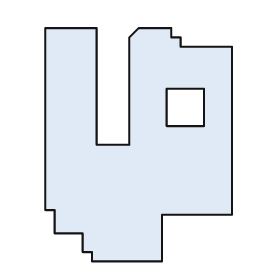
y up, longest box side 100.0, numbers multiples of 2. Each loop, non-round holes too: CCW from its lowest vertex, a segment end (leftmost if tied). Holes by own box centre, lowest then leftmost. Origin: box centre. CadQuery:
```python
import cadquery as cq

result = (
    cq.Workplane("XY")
    .moveTo(-20.0, -50.0)
    .lineTo(10.0, -50.0)
    .lineTo(10.0, -30.0)
    .lineTo(40.0, -30.0)
    .lineTo(40.0, 42.0)
    .lineTo(18.0, 42.0)
    .lineTo(18.0, 46.0)
    .lineTo(14.0, 46.0)
    .lineTo(14.0, 50.0)
    .lineTo(0.0, 50.0)
    .lineTo(-4.0, 46.0)
    .lineTo(-4.0, 0.0)
    .lineTo(-18.0, 0.0)
    .lineTo(-18.0, 50.0)
    .lineTo(-40.0, 50.0)
    .lineTo(-40.0, -28.0)
    .lineTo(-36.0, -28.0)
    .lineTo(-36.0, -38.0)
    .lineTo(-24.0, -38.0)
    .lineTo(-24.0, -46.0)
    .lineTo(-20.0, -46.0)
    .close()
    .moveTo(12.0, 8.0)
    .lineTo(28.0, 8.0)
    .lineTo(28.0, 24.0)
    .lineTo(12.0, 24.0)
    .close()
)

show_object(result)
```